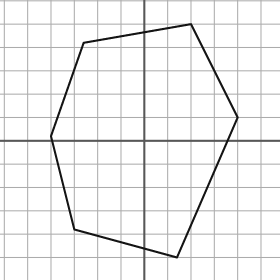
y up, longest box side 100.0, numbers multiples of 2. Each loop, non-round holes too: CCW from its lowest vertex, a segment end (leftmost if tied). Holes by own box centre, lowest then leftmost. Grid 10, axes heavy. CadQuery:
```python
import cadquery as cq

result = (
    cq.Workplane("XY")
    .moveTo(14.0, -50.0)
    .lineTo(40.0, 10.0)
    .lineTo(20.0, 50.0)
    .lineTo(-26.0, 42.0)
    .lineTo(-40.0, 2.0)
    .lineTo(-30.0, -38.0)
    .close()
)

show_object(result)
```